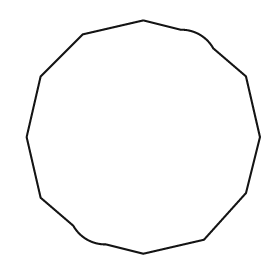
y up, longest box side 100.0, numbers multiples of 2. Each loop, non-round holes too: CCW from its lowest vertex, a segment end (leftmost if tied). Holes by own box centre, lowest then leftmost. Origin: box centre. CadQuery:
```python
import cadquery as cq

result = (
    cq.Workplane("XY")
    .moveTo(0.0, -50.0)
    .lineTo(26.0, -44.0)
    .lineTo(44.0, -24.0)
    .lineTo(50.0, 0.0)
    .lineTo(44.0, 26.0)
    .lineTo(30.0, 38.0)
    .threePointArc((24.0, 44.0), (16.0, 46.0))
    .lineTo(0.0, 50.0)
    .lineTo(-26.0, 44.0)
    .lineTo(-44.0, 26.0)
    .lineTo(-50.0, 0.0)
    .lineTo(-44.0, -26.0)
    .lineTo(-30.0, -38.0)
    .threePointArc((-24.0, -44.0), (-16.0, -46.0))
    .close()
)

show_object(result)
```